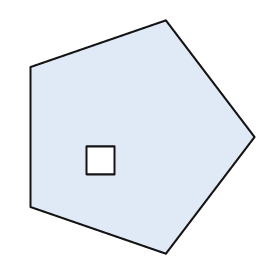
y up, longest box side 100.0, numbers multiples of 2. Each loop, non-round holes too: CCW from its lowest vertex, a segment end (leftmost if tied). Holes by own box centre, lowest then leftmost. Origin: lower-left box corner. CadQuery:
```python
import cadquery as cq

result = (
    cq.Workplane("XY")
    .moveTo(58.0, 0.0)
    .lineTo(96.0, 50.0)
    .lineTo(58.0, 100.0)
    .lineTo(0.0, 80.0)
    .lineTo(0.0, 20.0)
    .close()
    .moveTo(24.0, 34.0)
    .lineTo(36.0, 34.0)
    .lineTo(36.0, 46.0)
    .lineTo(24.0, 46.0)
    .close()
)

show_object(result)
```